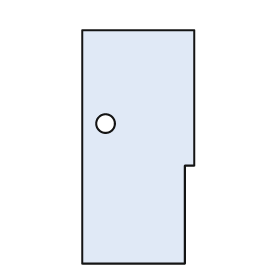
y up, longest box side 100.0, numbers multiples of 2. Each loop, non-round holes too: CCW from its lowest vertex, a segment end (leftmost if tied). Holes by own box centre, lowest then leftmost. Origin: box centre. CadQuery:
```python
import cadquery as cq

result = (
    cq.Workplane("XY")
    .moveTo(-24.0, -50.0)
    .lineTo(20.0, -50.0)
    .lineTo(20.0, -8.0)
    .lineTo(24.0, -8.0)
    .lineTo(24.0, 50.0)
    .lineTo(-24.0, 50.0)
    .close()
    .moveTo(-14.0, 10.0)
    .circle(4.0)
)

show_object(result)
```